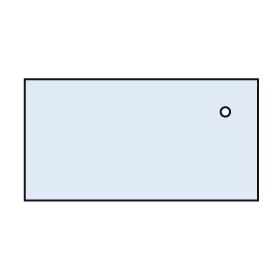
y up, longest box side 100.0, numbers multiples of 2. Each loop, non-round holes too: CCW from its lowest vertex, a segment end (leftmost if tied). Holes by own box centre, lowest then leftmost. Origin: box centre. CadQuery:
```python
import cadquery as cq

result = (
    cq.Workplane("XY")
    .moveTo(-50.0, -26.0)
    .lineTo(50.0, -26.0)
    .lineTo(50.0, 26.0)
    .lineTo(-50.0, 26.0)
    .close()
    .moveTo(36.0, 12.0)
    .circle(2.0)
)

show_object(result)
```